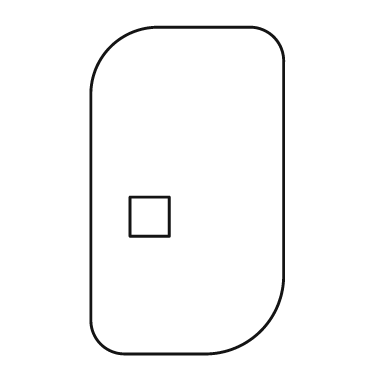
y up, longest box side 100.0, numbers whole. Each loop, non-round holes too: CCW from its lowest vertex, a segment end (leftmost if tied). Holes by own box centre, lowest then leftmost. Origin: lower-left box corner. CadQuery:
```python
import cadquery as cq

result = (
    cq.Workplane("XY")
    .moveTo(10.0, 0.0)
    .lineTo(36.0, 0.0)
    .threePointArc((52.0, 7.0), (59.0, 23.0))
    .lineTo(59.0, 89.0)
    .threePointArc((56.0, 97.0), (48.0, 100.0))
    .lineTo(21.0, 100.0)
    .threePointArc((6.0, 94.0), (0.0, 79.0))
    .lineTo(0.0, 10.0)
    .threePointArc((3.0, 3.0), (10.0, 0.0))
    .close()
    .moveTo(12.0, 36.0)
    .lineTo(24.0, 36.0)
    .lineTo(24.0, 48.0)
    .lineTo(12.0, 48.0)
    .close()
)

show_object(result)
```